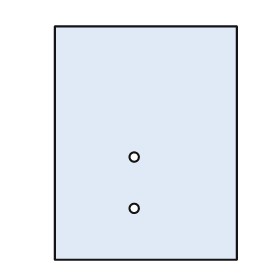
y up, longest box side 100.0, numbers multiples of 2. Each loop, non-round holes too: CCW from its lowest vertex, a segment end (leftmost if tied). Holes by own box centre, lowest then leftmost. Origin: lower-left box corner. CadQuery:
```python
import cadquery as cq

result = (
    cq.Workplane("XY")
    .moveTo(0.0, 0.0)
    .lineTo(78.0, 0.0)
    .lineTo(78.0, 100.0)
    .lineTo(0.0, 100.0)
    .close()
    .moveTo(34.0, 22.0)
    .circle(2.0)
    .moveTo(34.0, 44.0)
    .circle(2.0)
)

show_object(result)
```